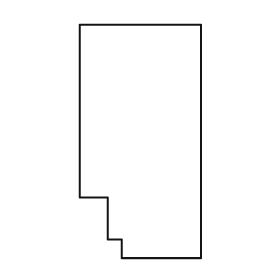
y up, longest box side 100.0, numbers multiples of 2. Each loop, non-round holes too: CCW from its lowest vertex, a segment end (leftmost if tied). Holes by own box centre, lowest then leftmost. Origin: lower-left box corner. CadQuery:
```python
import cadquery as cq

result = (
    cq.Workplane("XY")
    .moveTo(18.0, 0.0)
    .lineTo(52.0, 0.0)
    .lineTo(52.0, 100.0)
    .lineTo(0.0, 100.0)
    .lineTo(0.0, 26.0)
    .lineTo(12.0, 26.0)
    .lineTo(12.0, 8.0)
    .lineTo(18.0, 8.0)
    .close()
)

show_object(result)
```